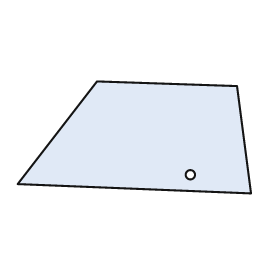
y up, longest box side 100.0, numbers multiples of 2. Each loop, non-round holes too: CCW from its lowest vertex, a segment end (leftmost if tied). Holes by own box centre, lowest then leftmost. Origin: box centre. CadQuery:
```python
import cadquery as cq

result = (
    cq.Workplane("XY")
    .moveTo(50.0, -24.0)
    .lineTo(44.0, 22.0)
    .lineTo(-16.0, 24.0)
    .lineTo(-50.0, -20.0)
    .close()
    .moveTo(24.0, -16.0)
    .circle(2.0)
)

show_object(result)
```